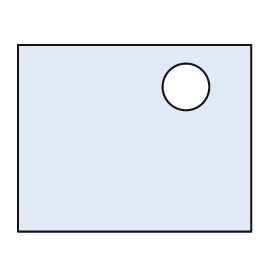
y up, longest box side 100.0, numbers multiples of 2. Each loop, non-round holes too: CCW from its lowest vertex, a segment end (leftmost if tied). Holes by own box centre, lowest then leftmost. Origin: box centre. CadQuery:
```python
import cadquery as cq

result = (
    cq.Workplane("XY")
    .moveTo(-50.0, -40.0)
    .lineTo(50.0, -40.0)
    .lineTo(50.0, 40.0)
    .lineTo(-50.0, 40.0)
    .close()
    .moveTo(22.0, 22.0)
    .circle(10.0)
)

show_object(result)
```